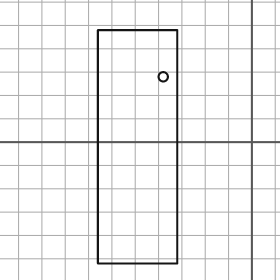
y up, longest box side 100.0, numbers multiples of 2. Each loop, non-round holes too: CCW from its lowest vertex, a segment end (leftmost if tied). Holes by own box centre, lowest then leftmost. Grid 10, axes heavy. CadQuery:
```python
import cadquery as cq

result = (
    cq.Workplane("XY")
    .moveTo(-66.0, -52.0)
    .lineTo(-32.0, -52.0)
    .lineTo(-32.0, 48.0)
    .lineTo(-66.0, 48.0)
    .close()
    .moveTo(-38.0, 28.0)
    .circle(2.0)
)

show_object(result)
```